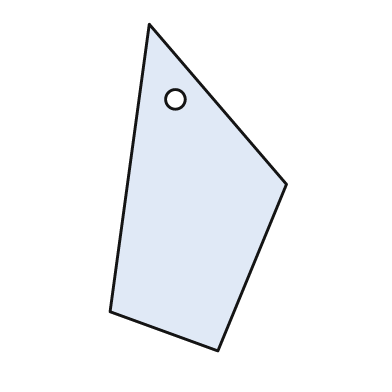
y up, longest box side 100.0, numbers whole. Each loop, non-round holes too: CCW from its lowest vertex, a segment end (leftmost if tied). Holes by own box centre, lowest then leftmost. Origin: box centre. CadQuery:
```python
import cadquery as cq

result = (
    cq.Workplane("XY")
    .moveTo(6.0, -50.0)
    .lineTo(27.0, 1.0)
    .lineTo(-15.0, 50.0)
    .lineTo(-27.0, -38.0)
    .close()
    .moveTo(-7.0, 27.0)
    .circle(3.0)
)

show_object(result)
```